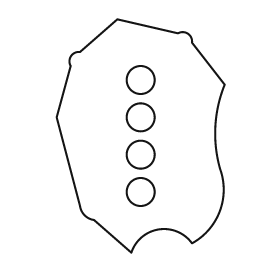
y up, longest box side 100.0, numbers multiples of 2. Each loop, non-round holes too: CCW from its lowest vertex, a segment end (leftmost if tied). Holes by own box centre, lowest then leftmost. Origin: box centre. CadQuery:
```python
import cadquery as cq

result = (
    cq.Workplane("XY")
    .moveTo(-4.0, -50.0)
    .threePointArc((8.0, -40.0), (22.0, -46.0))
    .threePointArc((34.0, -32.0), (34.0, -14.0))
    .threePointArc((32.0, 4.0), (36.0, 22.0))
    .lineTo(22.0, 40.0)
    .threePointArc((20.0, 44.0), (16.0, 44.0))
    .lineTo(-10.0, 50.0)
    .lineTo(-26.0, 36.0)
    .threePointArc((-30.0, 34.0), (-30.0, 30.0))
    .lineTo(-36.0, 8.0)
    .lineTo(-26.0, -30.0)
    .threePointArc((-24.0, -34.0), (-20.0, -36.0))
    .close()
    .moveTo(0.0, -24.0)
    .circle(6.0)
    .moveTo(0.0, -8.0)
    .circle(6.0)
    .moveTo(0.0, 8.0)
    .circle(6.0)
    .moveTo(0.0, 24.0)
    .circle(6.0)
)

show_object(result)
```